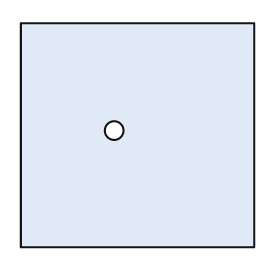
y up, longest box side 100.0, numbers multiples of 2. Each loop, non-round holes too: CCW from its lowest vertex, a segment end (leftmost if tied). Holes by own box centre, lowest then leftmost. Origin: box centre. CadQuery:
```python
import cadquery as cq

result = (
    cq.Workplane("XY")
    .moveTo(-50.0, -48.0)
    .lineTo(50.0, -48.0)
    .lineTo(50.0, 48.0)
    .lineTo(-50.0, 48.0)
    .close()
    .moveTo(-10.0, 2.0)
    .circle(4.0)
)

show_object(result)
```